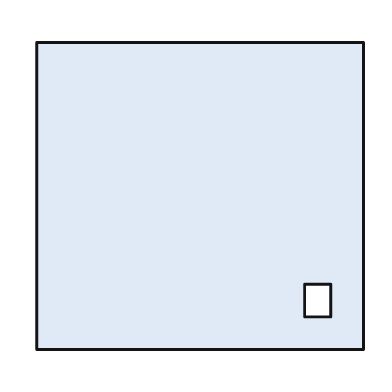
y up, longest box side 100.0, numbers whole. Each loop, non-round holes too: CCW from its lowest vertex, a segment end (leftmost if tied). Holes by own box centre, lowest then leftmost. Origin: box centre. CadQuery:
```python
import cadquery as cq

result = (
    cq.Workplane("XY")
    .moveTo(-50.0, -47.0)
    .lineTo(50.0, -47.0)
    .lineTo(50.0, 47.0)
    .lineTo(-50.0, 47.0)
    .close()
    .moveTo(32.0, -37.0)
    .lineTo(40.0, -37.0)
    .lineTo(40.0, -27.0)
    .lineTo(32.0, -27.0)
    .close()
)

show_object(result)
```